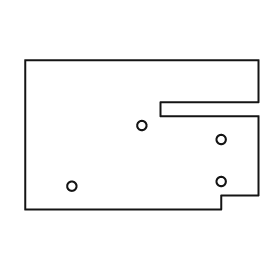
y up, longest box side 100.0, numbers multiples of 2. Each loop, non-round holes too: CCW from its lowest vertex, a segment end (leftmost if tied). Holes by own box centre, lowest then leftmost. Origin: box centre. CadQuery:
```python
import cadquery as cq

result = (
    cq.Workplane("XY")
    .moveTo(-50.0, -32.0)
    .lineTo(34.0, -32.0)
    .lineTo(34.0, -26.0)
    .lineTo(50.0, -26.0)
    .lineTo(50.0, 8.0)
    .lineTo(8.0, 8.0)
    .lineTo(8.0, 14.0)
    .lineTo(50.0, 14.0)
    .lineTo(50.0, 32.0)
    .lineTo(-50.0, 32.0)
    .close()
    .moveTo(-30.0, -22.0)
    .circle(2.0)
    .moveTo(34.0, -20.0)
    .circle(2.0)
    .moveTo(34.0, -2.0)
    .circle(2.0)
    .moveTo(0.0, 4.0)
    .circle(2.0)
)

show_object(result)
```